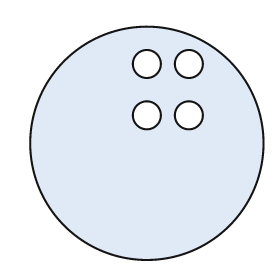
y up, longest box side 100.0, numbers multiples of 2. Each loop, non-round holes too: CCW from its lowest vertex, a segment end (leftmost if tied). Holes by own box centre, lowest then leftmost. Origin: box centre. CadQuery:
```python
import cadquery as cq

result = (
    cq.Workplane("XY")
    .moveTo(0.0, 0.0)
    .circle(50.0)
    .moveTo(0.0, 12.0)
    .circle(6.0)
    .moveTo(18.0, 12.0)
    .circle(6.0)
    .moveTo(0.0, 34.0)
    .circle(6.0)
    .moveTo(18.0, 34.0)
    .circle(6.0)
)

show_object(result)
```